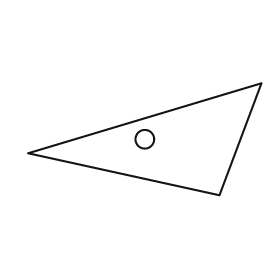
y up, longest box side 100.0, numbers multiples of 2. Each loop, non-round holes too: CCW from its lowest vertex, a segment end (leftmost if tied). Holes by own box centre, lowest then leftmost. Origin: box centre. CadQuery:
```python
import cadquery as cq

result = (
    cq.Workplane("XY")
    .moveTo(32.0, -24.0)
    .lineTo(50.0, 24.0)
    .lineTo(-50.0, -6.0)
    .close()
    .moveTo(0.0, 0.0)
    .circle(4.0)
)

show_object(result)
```